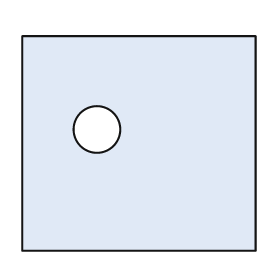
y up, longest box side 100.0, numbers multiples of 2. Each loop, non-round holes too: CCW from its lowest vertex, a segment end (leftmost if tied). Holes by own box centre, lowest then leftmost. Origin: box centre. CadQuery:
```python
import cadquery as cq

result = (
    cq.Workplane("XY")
    .moveTo(-50.0, -46.0)
    .lineTo(50.0, -46.0)
    .lineTo(50.0, 46.0)
    .lineTo(-50.0, 46.0)
    .close()
    .moveTo(-18.0, 6.0)
    .circle(10.0)
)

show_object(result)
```